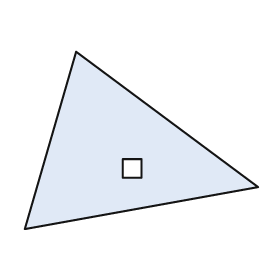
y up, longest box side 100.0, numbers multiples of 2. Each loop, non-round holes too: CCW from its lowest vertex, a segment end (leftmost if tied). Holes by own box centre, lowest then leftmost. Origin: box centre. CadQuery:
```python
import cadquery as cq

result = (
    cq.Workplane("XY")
    .moveTo(-50.0, -38.0)
    .lineTo(50.0, -20.0)
    .lineTo(-28.0, 38.0)
    .close()
    .moveTo(-8.0, -16.0)
    .lineTo(0.0, -16.0)
    .lineTo(0.0, -8.0)
    .lineTo(-8.0, -8.0)
    .close()
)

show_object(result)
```